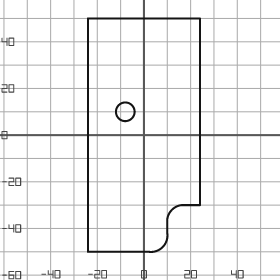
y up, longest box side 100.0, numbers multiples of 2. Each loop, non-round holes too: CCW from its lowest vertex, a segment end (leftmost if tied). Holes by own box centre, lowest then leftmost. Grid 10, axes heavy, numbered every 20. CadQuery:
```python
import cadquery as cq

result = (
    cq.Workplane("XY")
    .moveTo(-24.0, -50.0)
    .lineTo(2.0, -50.0)
    .threePointArc((8.0, -48.0), (10.0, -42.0))
    .lineTo(10.0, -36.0)
    .threePointArc((12.0, -32.0), (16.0, -30.0))
    .lineTo(24.0, -30.0)
    .lineTo(24.0, 50.0)
    .lineTo(-24.0, 50.0)
    .close()
    .moveTo(-8.0, 10.0)
    .circle(4.0)
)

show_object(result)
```